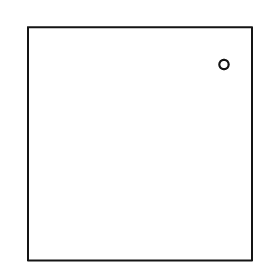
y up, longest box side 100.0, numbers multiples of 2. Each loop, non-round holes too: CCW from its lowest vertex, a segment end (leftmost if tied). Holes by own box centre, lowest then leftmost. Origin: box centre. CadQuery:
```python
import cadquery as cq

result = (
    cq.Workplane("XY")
    .moveTo(-48.0, -50.0)
    .lineTo(48.0, -50.0)
    .lineTo(48.0, 50.0)
    .lineTo(-48.0, 50.0)
    .close()
    .moveTo(36.0, 34.0)
    .circle(2.0)
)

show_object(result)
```